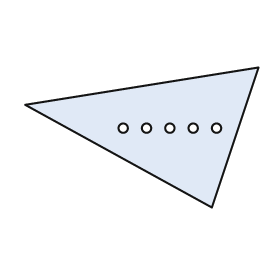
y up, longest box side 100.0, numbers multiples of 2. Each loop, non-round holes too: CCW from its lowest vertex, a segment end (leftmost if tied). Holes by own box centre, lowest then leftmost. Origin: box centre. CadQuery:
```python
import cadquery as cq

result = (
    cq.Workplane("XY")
    .moveTo(30.0, -30.0)
    .lineTo(50.0, 30.0)
    .lineTo(-50.0, 14.0)
    .close()
    .moveTo(-8.0, 4.0)
    .circle(2.0)
    .moveTo(2.0, 4.0)
    .circle(2.0)
    .moveTo(12.0, 4.0)
    .circle(2.0)
    .moveTo(22.0, 4.0)
    .circle(2.0)
    .moveTo(32.0, 4.0)
    .circle(2.0)
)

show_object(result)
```